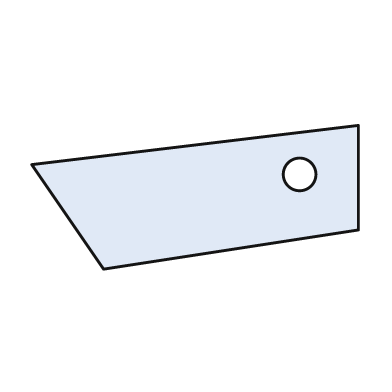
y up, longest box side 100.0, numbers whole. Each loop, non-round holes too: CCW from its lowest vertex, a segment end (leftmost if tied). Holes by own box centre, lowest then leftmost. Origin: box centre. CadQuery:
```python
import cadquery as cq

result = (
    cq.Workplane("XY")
    .moveTo(-28.0, -22.0)
    .lineTo(50.0, -10.0)
    .lineTo(50.0, 22.0)
    .lineTo(-50.0, 10.0)
    .close()
    .moveTo(32.0, 7.0)
    .circle(5.0)
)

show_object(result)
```